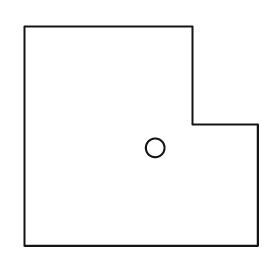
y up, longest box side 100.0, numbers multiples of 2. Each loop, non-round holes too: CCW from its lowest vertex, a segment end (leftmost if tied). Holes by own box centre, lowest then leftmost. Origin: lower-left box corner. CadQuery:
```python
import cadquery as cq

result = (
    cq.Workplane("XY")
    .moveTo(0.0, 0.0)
    .lineTo(100.0, 0.0)
    .lineTo(100.0, 52.0)
    .lineTo(72.0, 52.0)
    .lineTo(72.0, 94.0)
    .lineTo(0.0, 94.0)
    .close()
    .moveTo(56.0, 42.0)
    .circle(4.0)
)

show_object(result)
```